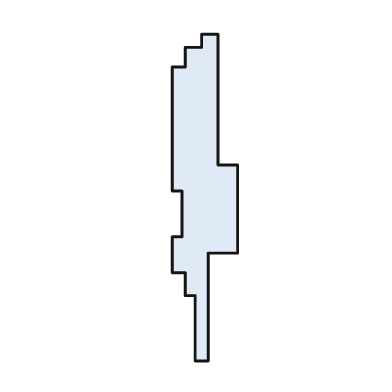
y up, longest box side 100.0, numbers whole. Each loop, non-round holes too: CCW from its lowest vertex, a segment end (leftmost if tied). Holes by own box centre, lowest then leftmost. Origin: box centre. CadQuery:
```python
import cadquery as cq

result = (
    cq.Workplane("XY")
    .moveTo(-3.0, -50.0)
    .lineTo(1.0, -50.0)
    .lineTo(1.0, -17.0)
    .lineTo(10.0, -17.0)
    .lineTo(10.0, 10.0)
    .lineTo(4.0, 10.0)
    .lineTo(4.0, 50.0)
    .lineTo(-1.0, 50.0)
    .lineTo(-1.0, 46.0)
    .lineTo(-6.0, 46.0)
    .lineTo(-6.0, 40.0)
    .lineTo(-10.0, 40.0)
    .lineTo(-10.0, 2.0)
    .lineTo(-7.0, 2.0)
    .lineTo(-7.0, -12.0)
    .lineTo(-10.0, -12.0)
    .lineTo(-10.0, -23.0)
    .lineTo(-6.0, -23.0)
    .lineTo(-6.0, -30.0)
    .lineTo(-3.0, -30.0)
    .close()
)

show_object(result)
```